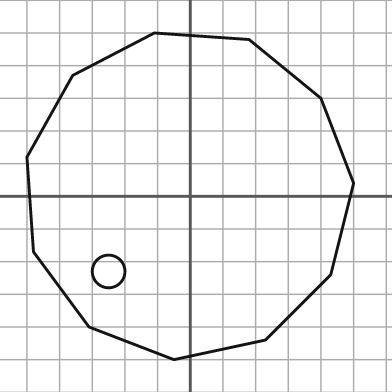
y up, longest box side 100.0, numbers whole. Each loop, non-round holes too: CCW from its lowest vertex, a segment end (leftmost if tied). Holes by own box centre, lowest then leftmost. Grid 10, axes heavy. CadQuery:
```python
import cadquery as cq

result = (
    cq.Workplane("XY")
    .moveTo(-5.0, -50.0)
    .lineTo(23.0, -44.0)
    .lineTo(43.0, -24.0)
    .lineTo(50.0, 4.0)
    .lineTo(40.0, 30.0)
    .lineTo(18.0, 48.0)
    .lineTo(-11.0, 50.0)
    .lineTo(-36.0, 37.0)
    .lineTo(-50.0, 12.0)
    .lineTo(-48.0, -17.0)
    .lineTo(-31.0, -40.0)
    .close()
    .moveTo(-25.0, -23.0)
    .circle(5.0)
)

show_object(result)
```